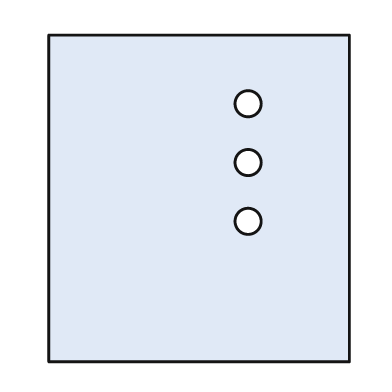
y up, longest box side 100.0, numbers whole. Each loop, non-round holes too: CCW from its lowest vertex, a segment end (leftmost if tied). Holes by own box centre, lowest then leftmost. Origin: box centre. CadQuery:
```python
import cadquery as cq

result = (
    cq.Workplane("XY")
    .moveTo(-46.0, -50.0)
    .lineTo(46.0, -50.0)
    .lineTo(46.0, 50.0)
    .lineTo(-46.0, 50.0)
    .close()
    .moveTo(15.0, -7.0)
    .circle(4.0)
    .moveTo(15.0, 11.0)
    .circle(4.0)
    .moveTo(15.0, 29.0)
    .circle(4.0)
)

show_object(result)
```